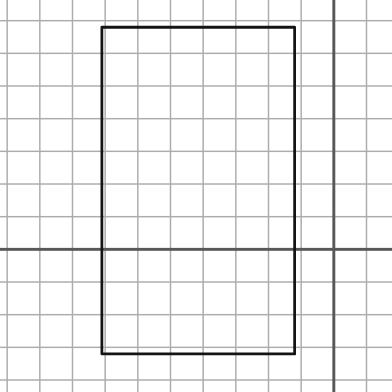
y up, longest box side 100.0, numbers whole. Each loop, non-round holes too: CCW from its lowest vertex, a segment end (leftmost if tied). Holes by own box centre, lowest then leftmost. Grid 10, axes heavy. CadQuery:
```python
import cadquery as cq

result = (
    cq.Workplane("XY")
    .moveTo(-71.0, -32.0)
    .lineTo(-12.0, -32.0)
    .lineTo(-12.0, 68.0)
    .lineTo(-71.0, 68.0)
    .close()
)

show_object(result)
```